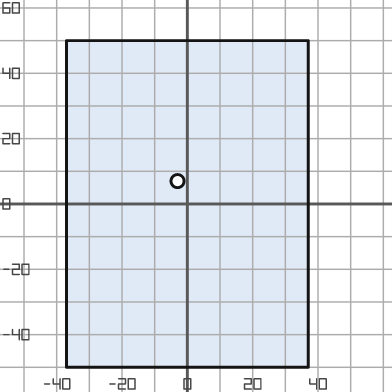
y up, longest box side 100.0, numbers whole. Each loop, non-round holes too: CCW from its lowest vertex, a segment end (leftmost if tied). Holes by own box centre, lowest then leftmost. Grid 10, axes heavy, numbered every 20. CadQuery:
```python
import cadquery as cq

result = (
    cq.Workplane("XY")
    .moveTo(-37.0, -50.0)
    .lineTo(37.0, -50.0)
    .lineTo(37.0, 50.0)
    .lineTo(-37.0, 50.0)
    .close()
    .moveTo(-3.0, 7.0)
    .circle(2.0)
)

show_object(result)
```